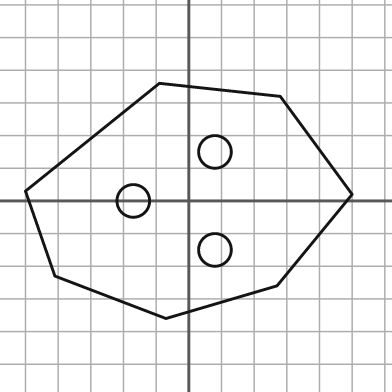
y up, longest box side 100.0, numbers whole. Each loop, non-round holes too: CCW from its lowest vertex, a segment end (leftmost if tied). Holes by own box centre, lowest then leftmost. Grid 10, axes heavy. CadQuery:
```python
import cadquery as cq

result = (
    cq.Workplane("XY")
    .moveTo(-7.0, -36.0)
    .lineTo(27.0, -26.0)
    .lineTo(50.0, 2.0)
    .lineTo(28.0, 32.0)
    .lineTo(-9.0, 36.0)
    .lineTo(-50.0, 3.0)
    .lineTo(-41.0, -23.0)
    .close()
    .moveTo(8.0, -15.0)
    .circle(5.0)
    .moveTo(-17.0, 0.0)
    .circle(5.0)
    .moveTo(8.0, 15.0)
    .circle(5.0)
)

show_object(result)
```